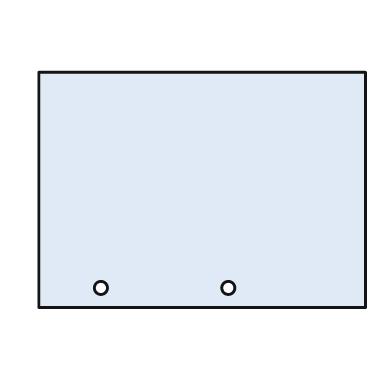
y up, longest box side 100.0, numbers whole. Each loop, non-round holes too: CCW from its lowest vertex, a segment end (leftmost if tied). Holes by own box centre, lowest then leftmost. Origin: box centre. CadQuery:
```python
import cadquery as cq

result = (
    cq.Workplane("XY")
    .moveTo(-50.0, -36.0)
    .lineTo(50.0, -36.0)
    .lineTo(50.0, 36.0)
    .lineTo(-50.0, 36.0)
    .close()
    .moveTo(-31.0, -30.0)
    .circle(2.0)
    .moveTo(8.0, -30.0)
    .circle(2.0)
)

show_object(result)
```